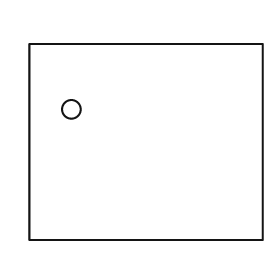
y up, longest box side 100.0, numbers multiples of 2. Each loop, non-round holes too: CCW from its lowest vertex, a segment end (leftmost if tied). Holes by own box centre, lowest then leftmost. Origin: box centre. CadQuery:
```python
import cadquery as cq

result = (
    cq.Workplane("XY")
    .moveTo(-50.0, -42.0)
    .lineTo(50.0, -42.0)
    .lineTo(50.0, 42.0)
    .lineTo(-50.0, 42.0)
    .close()
    .moveTo(-32.0, 14.0)
    .circle(4.0)
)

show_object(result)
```